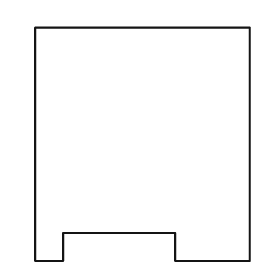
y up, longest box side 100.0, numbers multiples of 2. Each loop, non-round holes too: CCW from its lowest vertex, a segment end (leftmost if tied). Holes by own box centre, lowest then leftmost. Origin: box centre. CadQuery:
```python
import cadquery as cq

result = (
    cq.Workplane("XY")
    .moveTo(-46.0, -50.0)
    .lineTo(-34.0, -50.0)
    .lineTo(-34.0, -38.0)
    .lineTo(14.0, -38.0)
    .lineTo(14.0, -50.0)
    .lineTo(46.0, -50.0)
    .lineTo(46.0, 50.0)
    .lineTo(-46.0, 50.0)
    .close()
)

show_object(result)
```